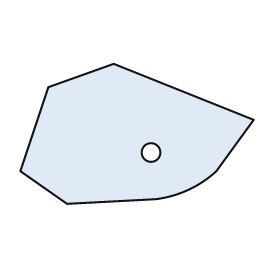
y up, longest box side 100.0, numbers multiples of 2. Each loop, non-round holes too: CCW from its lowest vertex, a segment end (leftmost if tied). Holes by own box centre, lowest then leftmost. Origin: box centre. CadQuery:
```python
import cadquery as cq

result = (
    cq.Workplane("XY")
    .moveTo(-30.0, -30.0)
    .lineTo(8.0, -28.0)
    .threePointArc((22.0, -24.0), (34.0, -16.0))
    .lineTo(50.0, 6.0)
    .lineTo(-10.0, 30.0)
    .lineTo(-38.0, 20.0)
    .lineTo(-50.0, -16.0)
    .close()
    .moveTo(6.0, -8.0)
    .circle(4.0)
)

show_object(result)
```